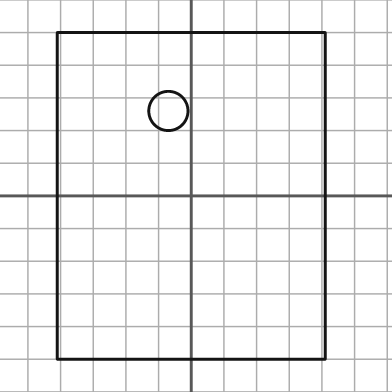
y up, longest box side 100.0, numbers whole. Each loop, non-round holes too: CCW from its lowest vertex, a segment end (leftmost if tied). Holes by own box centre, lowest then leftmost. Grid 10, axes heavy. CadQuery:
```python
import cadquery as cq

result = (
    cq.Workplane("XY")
    .moveTo(-41.0, -50.0)
    .lineTo(41.0, -50.0)
    .lineTo(41.0, 50.0)
    .lineTo(-41.0, 50.0)
    .close()
    .moveTo(-7.0, 26.0)
    .circle(6.0)
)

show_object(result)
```